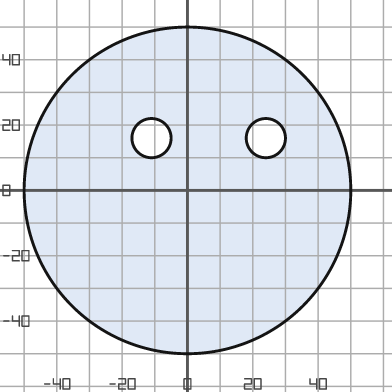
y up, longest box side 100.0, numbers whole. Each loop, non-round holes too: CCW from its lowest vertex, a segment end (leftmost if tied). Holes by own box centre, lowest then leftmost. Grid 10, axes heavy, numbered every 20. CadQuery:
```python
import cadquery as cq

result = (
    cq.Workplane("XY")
    .moveTo(0.0, 0.0)
    .circle(50.0)
    .moveTo(-11.0, 16.0)
    .circle(6.0)
    .moveTo(24.0, 16.0)
    .circle(6.0)
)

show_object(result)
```